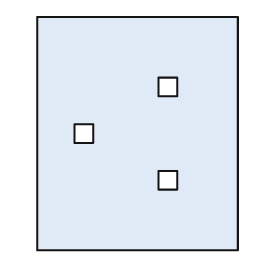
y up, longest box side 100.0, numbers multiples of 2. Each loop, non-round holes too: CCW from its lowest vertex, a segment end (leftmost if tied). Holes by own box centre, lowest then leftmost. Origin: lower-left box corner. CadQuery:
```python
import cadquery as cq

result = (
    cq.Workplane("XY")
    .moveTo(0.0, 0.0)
    .lineTo(86.0, 0.0)
    .lineTo(86.0, 100.0)
    .lineTo(0.0, 100.0)
    .close()
    .moveTo(52.0, 26.0)
    .lineTo(60.0, 26.0)
    .lineTo(60.0, 34.0)
    .lineTo(52.0, 34.0)
    .close()
    .moveTo(16.0, 46.0)
    .lineTo(24.0, 46.0)
    .lineTo(24.0, 54.0)
    .lineTo(16.0, 54.0)
    .close()
    .moveTo(52.0, 66.0)
    .lineTo(60.0, 66.0)
    .lineTo(60.0, 74.0)
    .lineTo(52.0, 74.0)
    .close()
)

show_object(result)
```